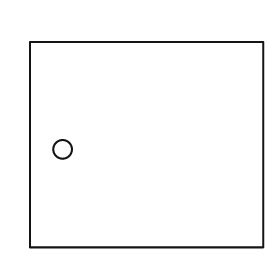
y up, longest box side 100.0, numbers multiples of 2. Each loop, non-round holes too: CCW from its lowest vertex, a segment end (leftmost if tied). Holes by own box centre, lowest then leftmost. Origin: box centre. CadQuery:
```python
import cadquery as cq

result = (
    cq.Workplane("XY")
    .moveTo(-50.0, -44.0)
    .lineTo(50.0, -44.0)
    .lineTo(50.0, 44.0)
    .lineTo(-50.0, 44.0)
    .close()
    .moveTo(-36.0, -2.0)
    .circle(4.0)
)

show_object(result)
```